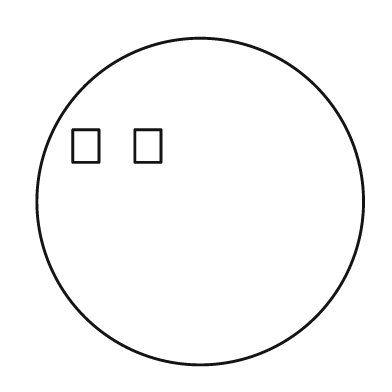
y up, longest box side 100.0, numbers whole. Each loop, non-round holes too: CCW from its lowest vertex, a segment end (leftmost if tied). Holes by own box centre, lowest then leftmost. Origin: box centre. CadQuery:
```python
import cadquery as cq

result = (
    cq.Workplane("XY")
    .moveTo(0.0, 0.0)
    .circle(50.0)
    .moveTo(-39.0, 12.0)
    .lineTo(-31.0, 12.0)
    .lineTo(-31.0, 22.0)
    .lineTo(-39.0, 22.0)
    .close()
    .moveTo(-20.0, 12.0)
    .lineTo(-12.0, 12.0)
    .lineTo(-12.0, 22.0)
    .lineTo(-20.0, 22.0)
    .close()
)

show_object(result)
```